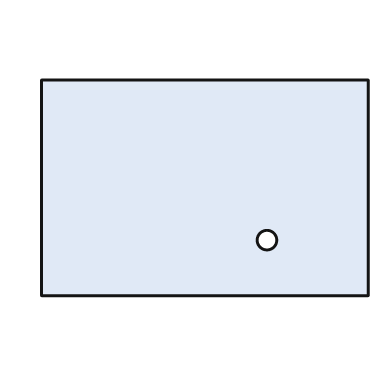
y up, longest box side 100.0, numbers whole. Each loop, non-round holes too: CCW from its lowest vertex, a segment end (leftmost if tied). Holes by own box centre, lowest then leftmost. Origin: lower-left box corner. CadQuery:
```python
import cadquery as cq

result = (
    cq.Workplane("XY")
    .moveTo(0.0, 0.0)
    .lineTo(100.0, 0.0)
    .lineTo(100.0, 66.0)
    .lineTo(0.0, 66.0)
    .close()
    .moveTo(69.0, 17.0)
    .circle(3.0)
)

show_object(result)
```